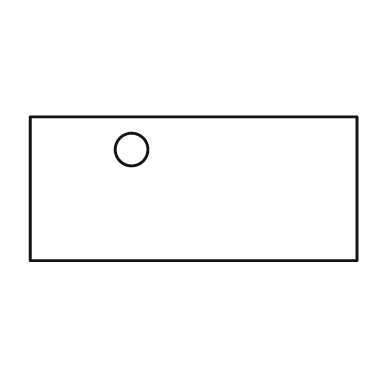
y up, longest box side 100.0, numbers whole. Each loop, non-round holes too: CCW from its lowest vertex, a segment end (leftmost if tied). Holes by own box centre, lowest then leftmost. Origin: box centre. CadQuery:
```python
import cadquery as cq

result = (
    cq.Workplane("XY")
    .moveTo(-50.0, -22.0)
    .lineTo(50.0, -22.0)
    .lineTo(50.0, 22.0)
    .lineTo(-50.0, 22.0)
    .close()
    .moveTo(-19.0, 12.0)
    .circle(5.0)
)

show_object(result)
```